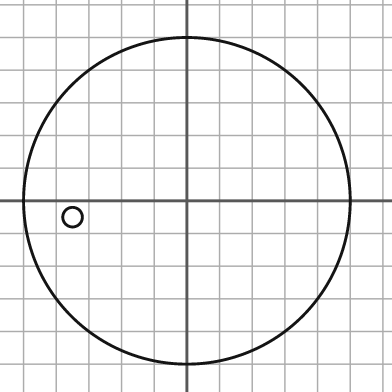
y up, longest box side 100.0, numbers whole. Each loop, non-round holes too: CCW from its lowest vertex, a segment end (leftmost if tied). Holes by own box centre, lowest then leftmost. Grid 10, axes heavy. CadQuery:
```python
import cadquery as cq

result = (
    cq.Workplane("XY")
    .moveTo(0.0, 0.0)
    .circle(50.0)
    .moveTo(-35.0, -5.0)
    .circle(3.0)
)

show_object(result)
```